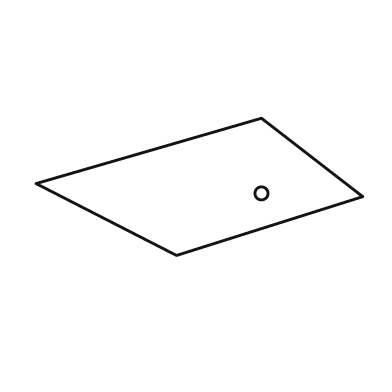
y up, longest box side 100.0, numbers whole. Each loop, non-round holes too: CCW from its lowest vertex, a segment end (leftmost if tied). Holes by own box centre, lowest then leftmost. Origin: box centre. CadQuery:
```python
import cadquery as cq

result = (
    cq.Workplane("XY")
    .moveTo(-7.0, -21.0)
    .lineTo(50.0, -3.0)
    .lineTo(19.0, 21.0)
    .lineTo(-50.0, 1.0)
    .close()
    .moveTo(19.0, -2.0)
    .circle(2.0)
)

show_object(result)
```